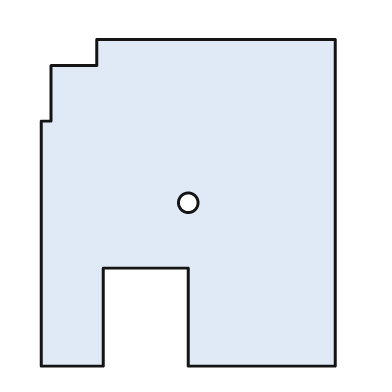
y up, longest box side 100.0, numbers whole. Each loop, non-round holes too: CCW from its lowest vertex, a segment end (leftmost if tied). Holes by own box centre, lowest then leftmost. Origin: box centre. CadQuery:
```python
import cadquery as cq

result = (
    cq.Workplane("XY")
    .moveTo(-45.0, -50.0)
    .lineTo(-26.0, -50.0)
    .lineTo(-26.0, -20.0)
    .lineTo(0.0, -20.0)
    .lineTo(0.0, -50.0)
    .lineTo(45.0, -50.0)
    .lineTo(45.0, 50.0)
    .lineTo(-28.0, 50.0)
    .lineTo(-28.0, 42.0)
    .lineTo(-42.0, 42.0)
    .lineTo(-42.0, 25.0)
    .lineTo(-45.0, 25.0)
    .close()
    .moveTo(0.0, 0.0)
    .circle(3.0)
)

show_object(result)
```